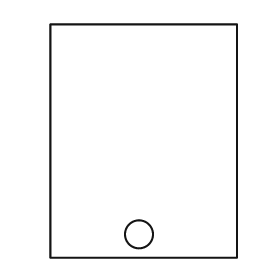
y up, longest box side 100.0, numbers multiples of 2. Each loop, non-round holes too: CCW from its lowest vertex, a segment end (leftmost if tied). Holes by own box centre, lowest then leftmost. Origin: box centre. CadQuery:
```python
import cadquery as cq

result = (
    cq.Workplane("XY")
    .moveTo(-40.0, -50.0)
    .lineTo(40.0, -50.0)
    .lineTo(40.0, 50.0)
    .lineTo(-40.0, 50.0)
    .close()
    .moveTo(-2.0, -40.0)
    .circle(6.0)
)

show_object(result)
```